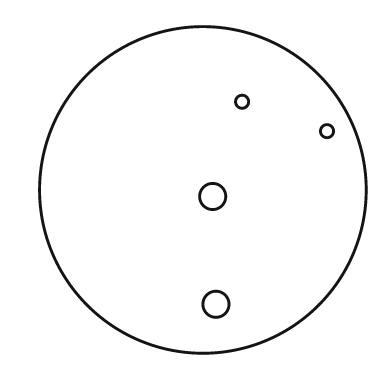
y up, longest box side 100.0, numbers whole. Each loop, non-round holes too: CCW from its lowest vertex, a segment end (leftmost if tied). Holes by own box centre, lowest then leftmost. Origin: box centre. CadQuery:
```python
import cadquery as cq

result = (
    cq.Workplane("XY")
    .moveTo(0.0, 0.0)
    .circle(50.0)
    .moveTo(4.0, -35.0)
    .circle(4.0)
    .moveTo(3.0, -2.0)
    .circle(4.0)
    .moveTo(38.0, 18.0)
    .circle(2.0)
    .moveTo(12.0, 27.0)
    .circle(2.0)
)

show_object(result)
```